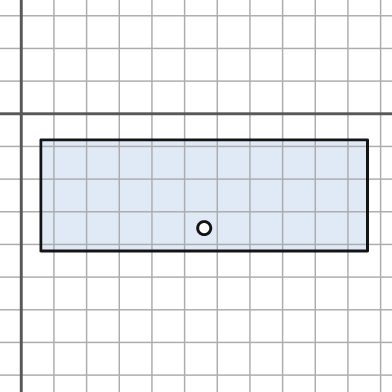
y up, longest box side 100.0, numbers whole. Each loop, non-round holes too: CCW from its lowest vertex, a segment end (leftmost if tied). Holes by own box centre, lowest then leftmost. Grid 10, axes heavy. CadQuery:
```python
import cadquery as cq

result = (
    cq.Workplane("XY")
    .moveTo(6.0, -42.0)
    .lineTo(106.0, -42.0)
    .lineTo(106.0, -8.0)
    .lineTo(6.0, -8.0)
    .close()
    .moveTo(56.0, -35.0)
    .circle(2.0)
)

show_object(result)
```